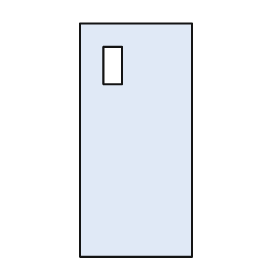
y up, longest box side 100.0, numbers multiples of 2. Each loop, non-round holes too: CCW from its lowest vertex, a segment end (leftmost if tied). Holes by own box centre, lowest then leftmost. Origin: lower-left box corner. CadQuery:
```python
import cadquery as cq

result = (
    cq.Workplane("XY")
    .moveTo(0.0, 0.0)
    .lineTo(48.0, 0.0)
    .lineTo(48.0, 100.0)
    .lineTo(0.0, 100.0)
    .close()
    .moveTo(10.0, 74.0)
    .lineTo(18.0, 74.0)
    .lineTo(18.0, 90.0)
    .lineTo(10.0, 90.0)
    .close()
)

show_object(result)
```